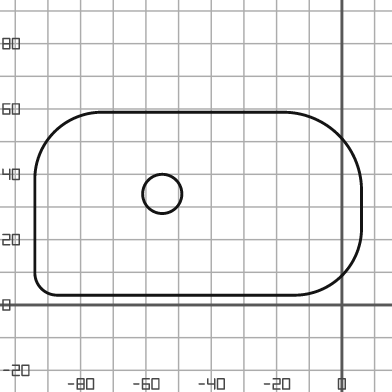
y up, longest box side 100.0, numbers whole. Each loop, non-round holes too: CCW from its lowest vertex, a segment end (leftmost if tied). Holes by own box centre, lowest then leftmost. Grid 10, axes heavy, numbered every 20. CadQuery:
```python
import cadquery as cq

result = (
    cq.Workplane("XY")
    .moveTo(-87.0, 3.0)
    .lineTo(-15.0, 3.0)
    .threePointArc((0.0, 9.0), (6.0, 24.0))
    .lineTo(6.0, 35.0)
    .threePointArc((-1.0, 52.0), (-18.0, 59.0))
    .lineTo(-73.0, 59.0)
    .threePointArc((-88.0, 53.0), (-94.0, 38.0))
    .lineTo(-94.0, 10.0)
    .threePointArc((-92.0, 5.0), (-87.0, 3.0))
    .close()
    .moveTo(-55.0, 34.0)
    .circle(6.0)
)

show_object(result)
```